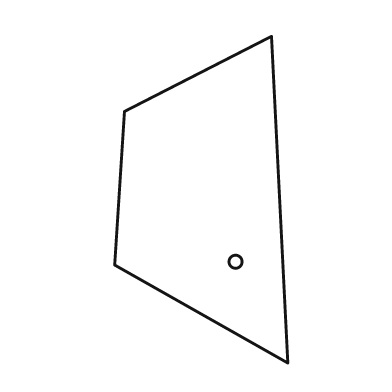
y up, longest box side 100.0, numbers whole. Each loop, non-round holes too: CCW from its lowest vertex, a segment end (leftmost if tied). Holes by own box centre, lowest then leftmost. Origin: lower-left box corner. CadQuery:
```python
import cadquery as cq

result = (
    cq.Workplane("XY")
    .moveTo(53.0, 0.0)
    .lineTo(48.0, 100.0)
    .lineTo(3.0, 77.0)
    .lineTo(0.0, 30.0)
    .close()
    .moveTo(37.0, 31.0)
    .circle(2.0)
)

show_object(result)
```